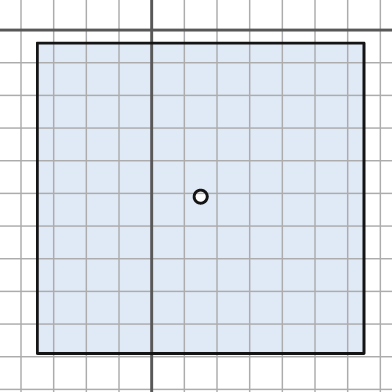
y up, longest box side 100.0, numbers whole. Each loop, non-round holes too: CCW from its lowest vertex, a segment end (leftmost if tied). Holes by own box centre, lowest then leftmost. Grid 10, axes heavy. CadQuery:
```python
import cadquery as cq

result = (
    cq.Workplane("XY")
    .moveTo(-35.0, -99.0)
    .lineTo(65.0, -99.0)
    .lineTo(65.0, -4.0)
    .lineTo(-35.0, -4.0)
    .close()
    .moveTo(15.0, -51.0)
    .circle(2.0)
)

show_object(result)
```